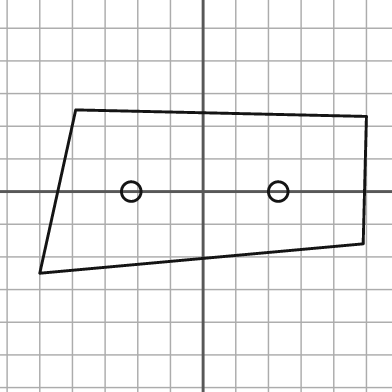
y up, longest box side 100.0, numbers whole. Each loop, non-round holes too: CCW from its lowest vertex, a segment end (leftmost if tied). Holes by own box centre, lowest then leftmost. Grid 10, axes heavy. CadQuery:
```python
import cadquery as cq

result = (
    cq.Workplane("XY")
    .moveTo(-50.0, -25.0)
    .lineTo(49.0, -16.0)
    .lineTo(50.0, 23.0)
    .lineTo(-39.0, 25.0)
    .close()
    .moveTo(-22.0, 0.0)
    .circle(3.0)
    .moveTo(23.0, 0.0)
    .circle(3.0)
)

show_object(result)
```